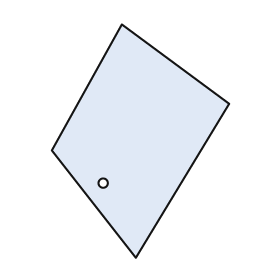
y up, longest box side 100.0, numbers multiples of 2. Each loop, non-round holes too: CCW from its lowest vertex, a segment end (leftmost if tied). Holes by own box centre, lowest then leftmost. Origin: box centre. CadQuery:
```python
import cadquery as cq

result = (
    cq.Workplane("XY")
    .moveTo(-2.0, -50.0)
    .lineTo(38.0, 16.0)
    .lineTo(-8.0, 50.0)
    .lineTo(-38.0, -4.0)
    .close()
    .moveTo(-16.0, -18.0)
    .circle(2.0)
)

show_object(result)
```